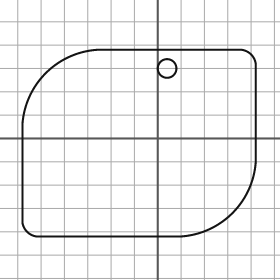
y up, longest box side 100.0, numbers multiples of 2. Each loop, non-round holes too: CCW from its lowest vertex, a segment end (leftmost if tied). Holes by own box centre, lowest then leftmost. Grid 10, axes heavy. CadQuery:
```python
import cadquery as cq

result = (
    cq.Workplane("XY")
    .moveTo(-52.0, -42.0)
    .lineTo(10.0, -42.0)
    .threePointArc((32.0, -32.0), (42.0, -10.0))
    .lineTo(42.0, 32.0)
    .threePointArc((40.0, 36.0), (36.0, 38.0))
    .lineTo(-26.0, 38.0)
    .threePointArc((-48.0, 28.0), (-58.0, 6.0))
    .lineTo(-58.0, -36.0)
    .threePointArc((-56.0, -40.0), (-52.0, -42.0))
    .close()
    .moveTo(4.0, 30.0)
    .circle(4.0)
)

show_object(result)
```